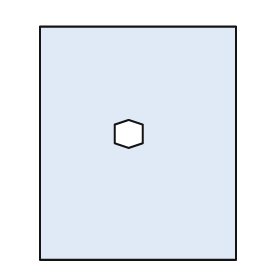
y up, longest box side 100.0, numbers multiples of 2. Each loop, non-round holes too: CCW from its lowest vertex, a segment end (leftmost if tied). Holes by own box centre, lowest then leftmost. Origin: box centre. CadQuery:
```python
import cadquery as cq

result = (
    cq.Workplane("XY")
    .moveTo(-42.0, -50.0)
    .lineTo(42.0, -50.0)
    .lineTo(42.0, 50.0)
    .lineTo(-42.0, 50.0)
    .close()
    .moveTo(-4.0, -2.0)
    .lineTo(2.0, 0.0)
    .lineTo(2.0, 8.0)
    .lineTo(-4.0, 10.0)
    .lineTo(-10.0, 8.0)
    .lineTo(-10.0, 0.0)
    .close()
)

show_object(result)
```